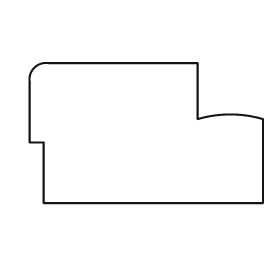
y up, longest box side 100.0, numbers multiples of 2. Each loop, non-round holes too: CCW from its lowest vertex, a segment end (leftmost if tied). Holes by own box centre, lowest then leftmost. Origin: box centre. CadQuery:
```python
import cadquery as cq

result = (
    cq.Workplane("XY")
    .moveTo(-44.0, -30.0)
    .lineTo(50.0, -30.0)
    .lineTo(50.0, 6.0)
    .threePointArc((36.0, 8.0), (22.0, 6.0))
    .lineTo(22.0, 30.0)
    .lineTo(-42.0, 30.0)
    .threePointArc((-48.0, 28.0), (-50.0, 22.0))
    .lineTo(-50.0, -4.0)
    .lineTo(-44.0, -4.0)
    .close()
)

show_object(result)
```